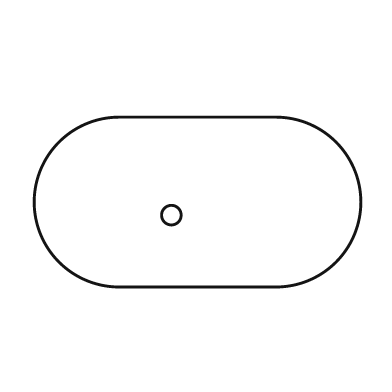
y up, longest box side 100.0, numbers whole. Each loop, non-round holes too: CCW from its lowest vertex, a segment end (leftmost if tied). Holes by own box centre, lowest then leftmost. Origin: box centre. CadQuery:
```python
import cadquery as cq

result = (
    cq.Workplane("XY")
    .moveTo(-24.0, -26.0)
    .lineTo(24.0, -26.0)
    .threePointArc((50.0, 0.0), (24.0, 26.0))
    .lineTo(-24.0, 26.0)
    .threePointArc((-50.0, 0.0), (-24.0, -26.0))
    .close()
    .moveTo(-8.0, -4.0)
    .circle(3.0)
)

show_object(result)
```